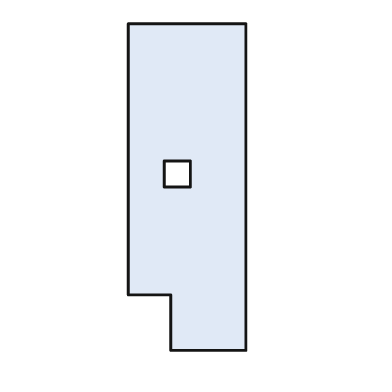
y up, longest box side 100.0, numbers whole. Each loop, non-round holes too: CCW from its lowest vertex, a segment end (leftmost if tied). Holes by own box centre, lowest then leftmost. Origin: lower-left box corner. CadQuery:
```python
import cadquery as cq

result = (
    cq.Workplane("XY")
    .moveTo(13.0, 0.0)
    .lineTo(36.0, 0.0)
    .lineTo(36.0, 100.0)
    .lineTo(0.0, 100.0)
    .lineTo(0.0, 17.0)
    .lineTo(13.0, 17.0)
    .close()
    .moveTo(11.0, 50.0)
    .lineTo(19.0, 50.0)
    .lineTo(19.0, 58.0)
    .lineTo(11.0, 58.0)
    .close()
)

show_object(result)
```